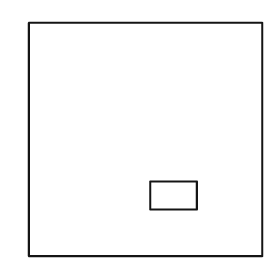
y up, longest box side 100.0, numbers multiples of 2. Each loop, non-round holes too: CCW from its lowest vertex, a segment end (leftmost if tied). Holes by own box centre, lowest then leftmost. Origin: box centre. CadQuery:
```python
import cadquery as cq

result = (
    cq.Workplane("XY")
    .moveTo(-50.0, -50.0)
    .lineTo(50.0, -50.0)
    .lineTo(50.0, 50.0)
    .lineTo(-50.0, 50.0)
    .close()
    .moveTo(2.0, -30.0)
    .lineTo(22.0, -30.0)
    .lineTo(22.0, -18.0)
    .lineTo(2.0, -18.0)
    .close()
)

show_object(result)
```